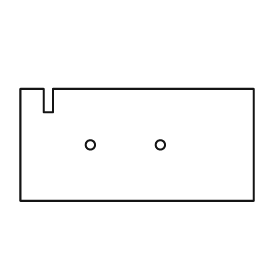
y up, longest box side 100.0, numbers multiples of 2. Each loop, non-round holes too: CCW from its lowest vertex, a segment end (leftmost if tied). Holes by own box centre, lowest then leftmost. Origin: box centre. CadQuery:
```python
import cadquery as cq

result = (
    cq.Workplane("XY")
    .moveTo(-50.0, -24.0)
    .lineTo(50.0, -24.0)
    .lineTo(50.0, 24.0)
    .lineTo(-36.0, 24.0)
    .lineTo(-36.0, 14.0)
    .lineTo(-40.0, 14.0)
    .lineTo(-40.0, 24.0)
    .lineTo(-50.0, 24.0)
    .close()
    .moveTo(-20.0, 0.0)
    .circle(2.0)
    .moveTo(10.0, 0.0)
    .circle(2.0)
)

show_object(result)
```